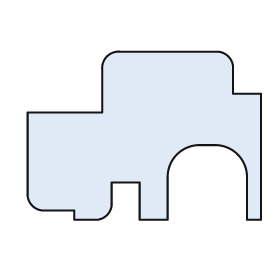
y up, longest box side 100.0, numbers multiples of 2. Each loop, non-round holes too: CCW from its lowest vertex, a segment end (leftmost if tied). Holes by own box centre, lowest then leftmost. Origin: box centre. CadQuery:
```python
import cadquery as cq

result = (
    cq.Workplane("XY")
    .moveTo(-30.0, -36.0)
    .lineTo(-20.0, -36.0)
    .threePointArc((-16.0, -34.0), (-14.0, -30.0))
    .lineTo(-14.0, -20.0)
    .lineTo(-2.0, -20.0)
    .lineTo(-2.0, -36.0)
    .lineTo(10.0, -36.0)
    .lineTo(10.0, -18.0)
    .threePointArc((14.0, -8.0), (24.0, -4.0))
    .lineTo(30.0, -4.0)
    .threePointArc((40.0, -8.0), (44.0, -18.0))
    .lineTo(44.0, -36.0)
    .lineTo(50.0, -36.0)
    .lineTo(50.0, 18.0)
    .lineTo(38.0, 18.0)
    .lineTo(38.0, 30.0)
    .threePointArc((36.0, 34.0), (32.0, 36.0))
    .lineTo(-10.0, 36.0)
    .threePointArc((-16.0, 34.0), (-18.0, 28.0))
    .lineTo(-18.0, 10.0)
    .lineTo(-50.0, 10.0)
    .lineTo(-50.0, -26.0)
    .threePointArc((-48.0, -30.0), (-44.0, -32.0))
    .lineTo(-30.0, -32.0)
    .close()
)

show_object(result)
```